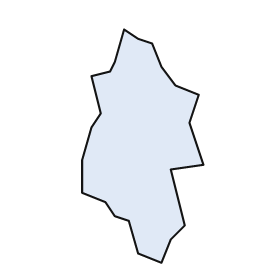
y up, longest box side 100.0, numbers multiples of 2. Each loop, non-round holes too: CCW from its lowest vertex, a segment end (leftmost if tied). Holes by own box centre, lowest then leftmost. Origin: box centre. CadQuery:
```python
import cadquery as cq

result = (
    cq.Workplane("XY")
    .moveTo(8.0, -50.0)
    .lineTo(12.0, -40.0)
    .lineTo(18.0, -34.0)
    .lineTo(12.0, -10.0)
    .lineTo(26.0, -8.0)
    .lineTo(20.0, 10.0)
    .lineTo(24.0, 22.0)
    .lineTo(14.0, 26.0)
    .lineTo(8.0, 34.0)
    .lineTo(4.0, 44.0)
    .lineTo(-2.0, 46.0)
    .lineTo(-8.0, 50.0)
    .lineTo(-12.0, 36.0)
    .lineTo(-14.0, 32.0)
    .lineTo(-22.0, 30.0)
    .lineTo(-18.0, 14.0)
    .lineTo(-22.0, 8.0)
    .lineTo(-26.0, -6.0)
    .lineTo(-26.0, -20.0)
    .lineTo(-16.0, -24.0)
    .lineTo(-12.0, -30.0)
    .lineTo(-6.0, -32.0)
    .lineTo(-2.0, -46.0)
    .close()
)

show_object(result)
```